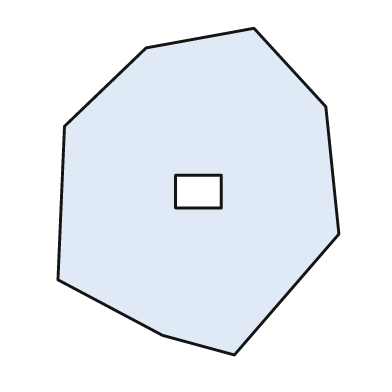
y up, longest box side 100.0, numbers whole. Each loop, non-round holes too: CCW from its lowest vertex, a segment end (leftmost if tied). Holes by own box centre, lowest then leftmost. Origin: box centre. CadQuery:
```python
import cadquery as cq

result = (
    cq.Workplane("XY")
    .moveTo(11.0, -50.0)
    .lineTo(43.0, -13.0)
    .lineTo(39.0, 26.0)
    .lineTo(17.0, 50.0)
    .lineTo(-16.0, 44.0)
    .lineTo(-41.0, 20.0)
    .lineTo(-43.0, -27.0)
    .lineTo(-11.0, -44.0)
    .close()
    .moveTo(-7.0, -5.0)
    .lineTo(7.0, -5.0)
    .lineTo(7.0, 5.0)
    .lineTo(-7.0, 5.0)
    .close()
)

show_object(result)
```